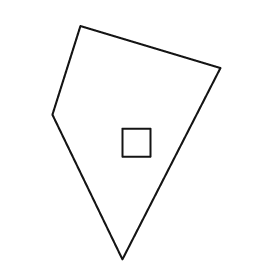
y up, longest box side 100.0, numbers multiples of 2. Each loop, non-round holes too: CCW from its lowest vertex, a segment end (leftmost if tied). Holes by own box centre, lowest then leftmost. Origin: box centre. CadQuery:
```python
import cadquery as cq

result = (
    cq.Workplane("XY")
    .moveTo(-6.0, -50.0)
    .lineTo(36.0, 32.0)
    .lineTo(-24.0, 50.0)
    .lineTo(-36.0, 12.0)
    .close()
    .moveTo(-6.0, -6.0)
    .lineTo(6.0, -6.0)
    .lineTo(6.0, 6.0)
    .lineTo(-6.0, 6.0)
    .close()
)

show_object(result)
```